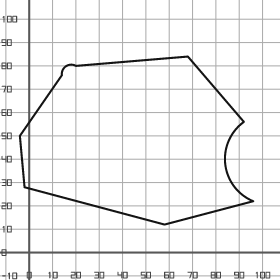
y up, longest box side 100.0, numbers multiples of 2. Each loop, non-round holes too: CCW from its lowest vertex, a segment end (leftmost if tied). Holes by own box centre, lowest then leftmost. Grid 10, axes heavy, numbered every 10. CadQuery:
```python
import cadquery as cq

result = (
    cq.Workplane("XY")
    .moveTo(58.0, 12.0)
    .lineTo(96.0, 22.0)
    .threePointArc((84.0, 38.0), (92.0, 56.0))
    .lineTo(68.0, 84.0)
    .lineTo(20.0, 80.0)
    .threePointArc((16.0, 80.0), (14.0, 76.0))
    .lineTo(-4.0, 50.0)
    .lineTo(-2.0, 28.0)
    .close()
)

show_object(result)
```